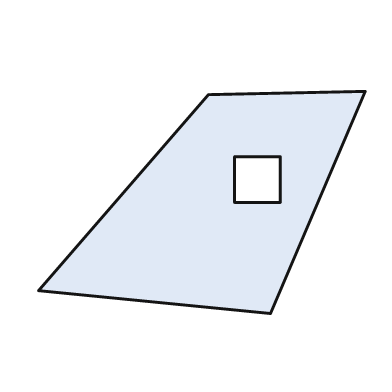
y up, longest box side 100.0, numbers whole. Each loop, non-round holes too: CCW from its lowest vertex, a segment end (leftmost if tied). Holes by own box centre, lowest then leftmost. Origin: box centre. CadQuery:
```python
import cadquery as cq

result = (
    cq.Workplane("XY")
    .moveTo(21.0, -34.0)
    .lineTo(50.0, 34.0)
    .lineTo(2.0, 33.0)
    .lineTo(-50.0, -27.0)
    .close()
    .moveTo(10.0, 0.0)
    .lineTo(24.0, 0.0)
    .lineTo(24.0, 14.0)
    .lineTo(10.0, 14.0)
    .close()
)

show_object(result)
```